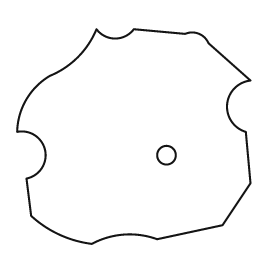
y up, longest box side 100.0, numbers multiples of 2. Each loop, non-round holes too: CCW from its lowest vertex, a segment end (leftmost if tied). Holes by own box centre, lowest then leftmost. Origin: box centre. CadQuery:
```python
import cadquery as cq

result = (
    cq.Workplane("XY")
    .moveTo(-18.0, -46.0)
    .threePointArc((-4.0, -42.0), (10.0, -44.0))
    .lineTo(38.0, -38.0)
    .lineTo(50.0, -20.0)
    .lineTo(48.0, 2.0)
    .threePointArc((40.0, 14.0), (50.0, 24.0))
    .lineTo(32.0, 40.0)
    .threePointArc((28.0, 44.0), (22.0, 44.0))
    .lineTo(0.0, 46.0)
    .threePointArc((-8.0, 42.0), (-16.0, 46.0))
    .threePointArc((-24.0, 34.0), (-36.0, 26.0))
    .threePointArc((-46.0, 16.0), (-50.0, 2.0))
    .threePointArc((-38.0, -6.0), (-46.0, -18.0))
    .lineTo(-44.0, -34.0)
    .threePointArc((-32.0, -42.0), (-18.0, -46.0))
    .close()
    .moveTo(14.0, -8.0)
    .circle(4.0)
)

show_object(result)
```